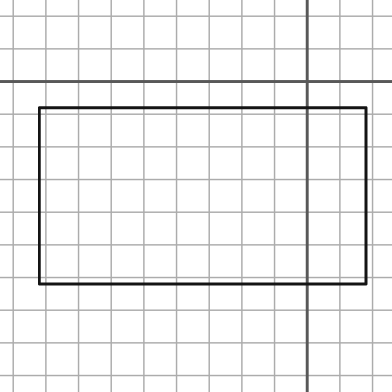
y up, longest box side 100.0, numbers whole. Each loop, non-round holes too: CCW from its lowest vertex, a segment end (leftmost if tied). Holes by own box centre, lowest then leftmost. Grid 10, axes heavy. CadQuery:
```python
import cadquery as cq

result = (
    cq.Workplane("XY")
    .moveTo(-82.0, -62.0)
    .lineTo(18.0, -62.0)
    .lineTo(18.0, -8.0)
    .lineTo(-82.0, -8.0)
    .close()
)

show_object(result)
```